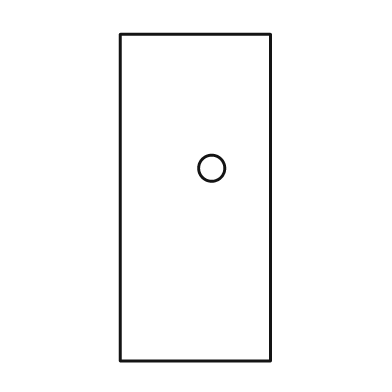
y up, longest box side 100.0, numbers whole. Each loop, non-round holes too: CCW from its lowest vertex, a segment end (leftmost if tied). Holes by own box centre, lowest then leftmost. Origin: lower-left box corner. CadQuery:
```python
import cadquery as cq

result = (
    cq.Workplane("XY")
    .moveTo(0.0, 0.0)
    .lineTo(46.0, 0.0)
    .lineTo(46.0, 100.0)
    .lineTo(0.0, 100.0)
    .close()
    .moveTo(28.0, 59.0)
    .circle(4.0)
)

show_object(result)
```